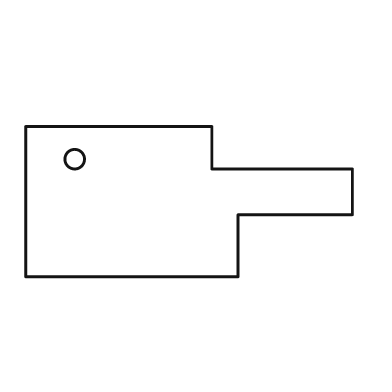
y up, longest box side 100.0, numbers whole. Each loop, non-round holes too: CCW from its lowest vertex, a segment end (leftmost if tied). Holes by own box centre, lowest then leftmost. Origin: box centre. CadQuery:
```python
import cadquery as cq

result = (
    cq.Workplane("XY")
    .moveTo(-50.0, -23.0)
    .lineTo(15.0, -23.0)
    .lineTo(15.0, -4.0)
    .lineTo(50.0, -4.0)
    .lineTo(50.0, 10.0)
    .lineTo(7.0, 10.0)
    .lineTo(7.0, 23.0)
    .lineTo(-50.0, 23.0)
    .close()
    .moveTo(-35.0, 13.0)
    .circle(3.0)
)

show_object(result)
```